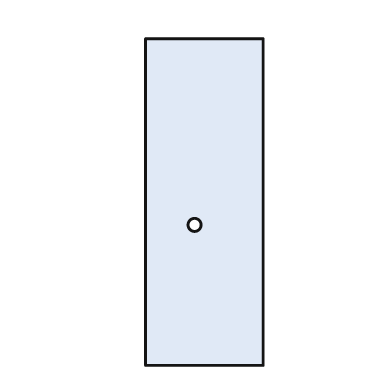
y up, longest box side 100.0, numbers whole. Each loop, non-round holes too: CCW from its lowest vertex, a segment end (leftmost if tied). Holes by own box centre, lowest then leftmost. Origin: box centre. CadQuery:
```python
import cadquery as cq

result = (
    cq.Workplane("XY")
    .moveTo(-18.0, -50.0)
    .lineTo(18.0, -50.0)
    .lineTo(18.0, 50.0)
    .lineTo(-18.0, 50.0)
    .close()
    .moveTo(-3.0, -7.0)
    .circle(2.0)
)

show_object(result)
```